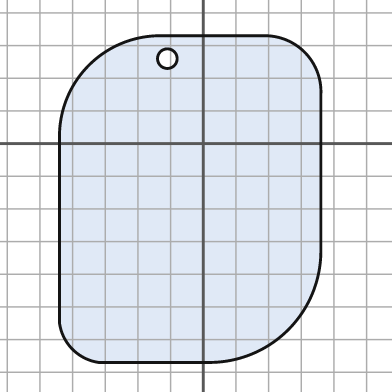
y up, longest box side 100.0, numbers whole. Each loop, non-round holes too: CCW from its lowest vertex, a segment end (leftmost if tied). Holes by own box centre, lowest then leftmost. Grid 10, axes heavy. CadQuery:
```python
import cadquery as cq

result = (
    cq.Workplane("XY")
    .moveTo(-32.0, -67.0)
    .lineTo(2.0, -67.0)
    .threePointArc((26.0, -57.0), (36.0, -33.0))
    .lineTo(36.0, 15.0)
    .threePointArc((31.0, 28.0), (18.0, 33.0))
    .lineTo(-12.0, 33.0)
    .threePointArc((-35.0, 24.0), (-44.0, 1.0))
    .lineTo(-44.0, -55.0)
    .threePointArc((-40.0, -63.0), (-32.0, -67.0))
    .close()
    .moveTo(-11.0, 26.0)
    .circle(3.0)
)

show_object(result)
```